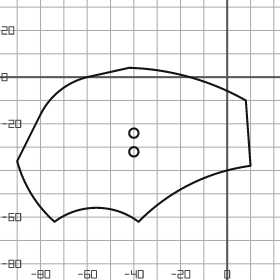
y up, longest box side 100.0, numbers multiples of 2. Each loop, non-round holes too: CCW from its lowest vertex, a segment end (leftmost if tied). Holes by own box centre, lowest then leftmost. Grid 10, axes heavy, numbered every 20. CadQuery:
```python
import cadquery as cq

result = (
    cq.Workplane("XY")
    .moveTo(-74.0, -62.0)
    .threePointArc((-56.0, -56.0), (-38.0, -62.0))
    .threePointArc((-16.0, -46.0), (10.0, -38.0))
    .lineTo(8.0, -10.0)
    .threePointArc((-16.0, 0.0), (-42.0, 4.0))
    .lineTo(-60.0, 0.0)
    .threePointArc((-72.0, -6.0), (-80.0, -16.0))
    .lineTo(-90.0, -36.0)
    .threePointArc((-84.0, -50.0), (-74.0, -62.0))
    .close()
    .moveTo(-40.0, -32.0)
    .circle(2.0)
    .moveTo(-40.0, -24.0)
    .circle(2.0)
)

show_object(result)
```